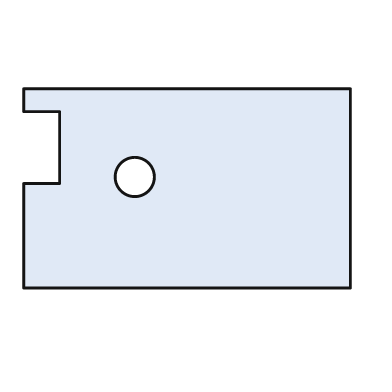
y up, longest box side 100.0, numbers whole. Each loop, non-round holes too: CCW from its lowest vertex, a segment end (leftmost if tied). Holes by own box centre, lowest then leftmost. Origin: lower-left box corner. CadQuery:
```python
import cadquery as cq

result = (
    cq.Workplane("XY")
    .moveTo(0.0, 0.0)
    .lineTo(100.0, 0.0)
    .lineTo(100.0, 61.0)
    .lineTo(0.0, 61.0)
    .lineTo(0.0, 54.0)
    .lineTo(11.0, 54.0)
    .lineTo(11.0, 32.0)
    .lineTo(0.0, 32.0)
    .close()
    .moveTo(34.0, 34.0)
    .circle(6.0)
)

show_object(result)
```